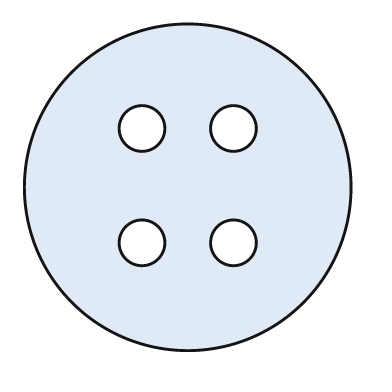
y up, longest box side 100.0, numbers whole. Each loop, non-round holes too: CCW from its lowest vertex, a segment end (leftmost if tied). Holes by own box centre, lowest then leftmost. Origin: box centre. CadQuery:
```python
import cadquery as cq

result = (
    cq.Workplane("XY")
    .moveTo(0.0, 0.0)
    .circle(50.0)
    .moveTo(-14.0, -17.0)
    .circle(7.0)
    .moveTo(14.0, -17.0)
    .circle(7.0)
    .moveTo(-14.0, 18.0)
    .circle(7.0)
    .moveTo(14.0, 18.0)
    .circle(7.0)
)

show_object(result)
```